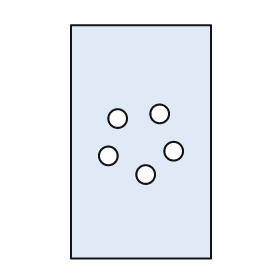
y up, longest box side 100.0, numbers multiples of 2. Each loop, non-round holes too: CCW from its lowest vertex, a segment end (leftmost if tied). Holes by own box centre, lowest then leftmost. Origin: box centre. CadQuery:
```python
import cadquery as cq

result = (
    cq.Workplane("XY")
    .moveTo(-30.0, -50.0)
    .lineTo(30.0, -50.0)
    .lineTo(30.0, 50.0)
    .lineTo(-30.0, 50.0)
    .close()
    .moveTo(2.0, -14.0)
    .circle(4.0)
    .moveTo(-14.0, -6.0)
    .circle(4.0)
    .moveTo(14.0, -4.0)
    .circle(4.0)
    .moveTo(-10.0, 10.0)
    .circle(4.0)
    .moveTo(8.0, 12.0)
    .circle(4.0)
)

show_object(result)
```